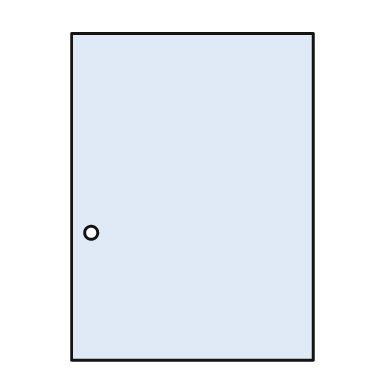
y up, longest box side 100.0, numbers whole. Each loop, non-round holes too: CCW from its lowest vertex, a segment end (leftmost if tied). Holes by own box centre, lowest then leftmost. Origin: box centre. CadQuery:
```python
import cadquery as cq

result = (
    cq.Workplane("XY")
    .moveTo(-37.0, -50.0)
    .lineTo(37.0, -50.0)
    .lineTo(37.0, 50.0)
    .lineTo(-37.0, 50.0)
    .close()
    .moveTo(-31.0, -11.0)
    .circle(2.0)
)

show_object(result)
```